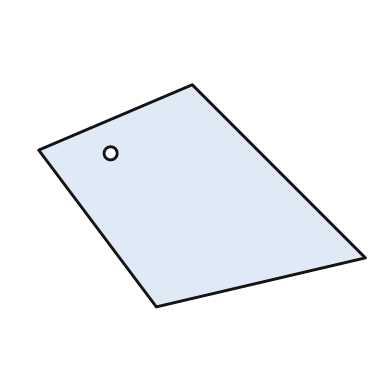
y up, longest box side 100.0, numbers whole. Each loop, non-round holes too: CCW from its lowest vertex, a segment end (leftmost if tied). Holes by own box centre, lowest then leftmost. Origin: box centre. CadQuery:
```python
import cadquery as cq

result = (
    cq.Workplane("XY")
    .moveTo(-14.0, -34.0)
    .lineTo(50.0, -19.0)
    .lineTo(-3.0, 34.0)
    .lineTo(-50.0, 14.0)
    .close()
    .moveTo(-28.0, 13.0)
    .circle(2.0)
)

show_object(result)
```